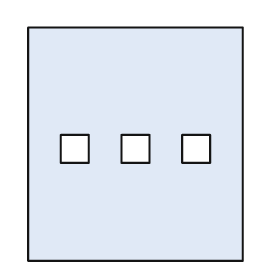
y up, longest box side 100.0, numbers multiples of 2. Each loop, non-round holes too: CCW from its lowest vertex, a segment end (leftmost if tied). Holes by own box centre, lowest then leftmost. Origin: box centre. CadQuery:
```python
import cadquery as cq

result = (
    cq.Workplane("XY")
    .moveTo(-46.0, -50.0)
    .lineTo(46.0, -50.0)
    .lineTo(46.0, 50.0)
    .lineTo(-46.0, 50.0)
    .close()
    .moveTo(-32.0, -8.0)
    .lineTo(-20.0, -8.0)
    .lineTo(-20.0, 4.0)
    .lineTo(-32.0, 4.0)
    .close()
    .moveTo(-6.0, -8.0)
    .lineTo(6.0, -8.0)
    .lineTo(6.0, 4.0)
    .lineTo(-6.0, 4.0)
    .close()
    .moveTo(20.0, -8.0)
    .lineTo(32.0, -8.0)
    .lineTo(32.0, 4.0)
    .lineTo(20.0, 4.0)
    .close()
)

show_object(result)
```